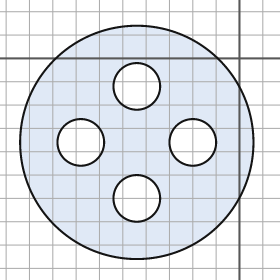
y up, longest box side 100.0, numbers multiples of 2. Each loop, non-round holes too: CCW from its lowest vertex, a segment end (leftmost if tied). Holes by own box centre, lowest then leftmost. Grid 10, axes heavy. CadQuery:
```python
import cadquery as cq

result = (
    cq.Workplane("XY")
    .moveTo(-44.0, -36.0)
    .circle(50.0)
    .moveTo(-44.0, -60.0)
    .circle(10.0)
    .moveTo(-68.0, -36.0)
    .circle(10.0)
    .moveTo(-20.0, -36.0)
    .circle(10.0)
    .moveTo(-44.0, -12.0)
    .circle(10.0)
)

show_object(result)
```